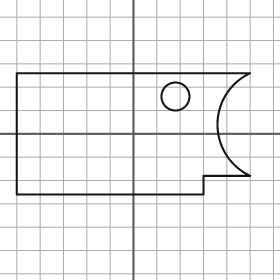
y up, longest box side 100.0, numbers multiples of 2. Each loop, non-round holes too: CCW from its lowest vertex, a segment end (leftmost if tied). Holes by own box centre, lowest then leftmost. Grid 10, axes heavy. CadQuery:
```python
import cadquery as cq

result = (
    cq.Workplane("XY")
    .moveTo(-50.0, -26.0)
    .lineTo(30.0, -26.0)
    .lineTo(30.0, -18.0)
    .lineTo(50.0, -18.0)
    .threePointArc((36.0, 4.0), (50.0, 26.0))
    .lineTo(-50.0, 26.0)
    .close()
    .moveTo(18.0, 16.0)
    .circle(6.0)
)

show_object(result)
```